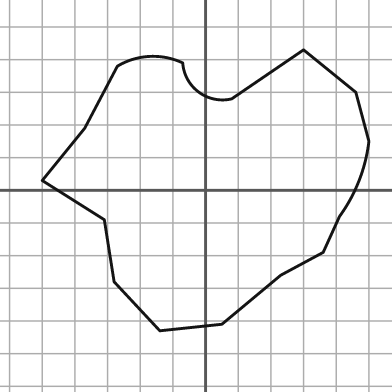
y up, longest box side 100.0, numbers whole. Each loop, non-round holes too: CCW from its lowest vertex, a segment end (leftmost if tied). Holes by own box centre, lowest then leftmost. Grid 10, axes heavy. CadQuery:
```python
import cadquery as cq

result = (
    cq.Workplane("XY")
    .moveTo(-14.0, -43.0)
    .lineTo(5.0, -41.0)
    .lineTo(23.0, -26.0)
    .lineTo(36.0, -19.0)
    .lineTo(41.0, -8.0)
    .threePointArc((47.0, 3.0), (50.0, 15.0))
    .lineTo(46.0, 30.0)
    .lineTo(30.0, 43.0)
    .lineTo(8.0, 28.0)
    .threePointArc((-2.0, 30.0), (-7.0, 39.0))
    .threePointArc((-17.0, 41.0), (-27.0, 38.0))
    .lineTo(-37.0, 19.0)
    .lineTo(-50.0, 3.0)
    .lineTo(-31.0, -9.0)
    .lineTo(-28.0, -28.0)
    .close()
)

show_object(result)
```